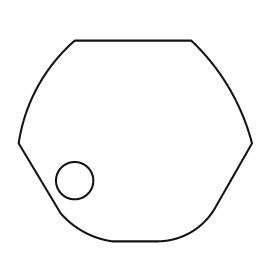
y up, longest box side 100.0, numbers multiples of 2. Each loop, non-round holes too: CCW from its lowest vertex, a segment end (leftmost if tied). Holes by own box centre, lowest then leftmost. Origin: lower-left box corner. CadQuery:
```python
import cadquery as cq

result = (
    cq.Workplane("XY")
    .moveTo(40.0, 0.0)
    .lineTo(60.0, 0.0)
    .threePointArc((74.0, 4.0), (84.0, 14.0))
    .lineTo(100.0, 42.0)
    .threePointArc((90.0, 66.0), (74.0, 86.0))
    .lineTo(24.0, 86.0)
    .threePointArc((8.0, 66.0), (0.0, 42.0))
    .lineTo(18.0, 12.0)
    .threePointArc((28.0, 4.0), (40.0, 0.0))
    .close()
    .moveTo(24.0, 26.0)
    .circle(8.0)
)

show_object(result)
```